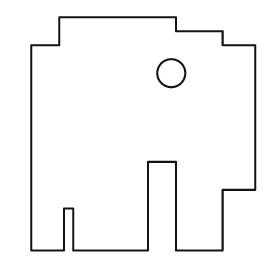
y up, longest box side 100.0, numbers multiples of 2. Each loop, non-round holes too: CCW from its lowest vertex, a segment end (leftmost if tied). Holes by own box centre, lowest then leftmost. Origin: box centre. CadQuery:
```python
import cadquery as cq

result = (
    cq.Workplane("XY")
    .moveTo(-48.0, -50.0)
    .lineTo(-34.0, -50.0)
    .lineTo(-34.0, -32.0)
    .lineTo(-30.0, -32.0)
    .lineTo(-30.0, -50.0)
    .lineTo(2.0, -50.0)
    .lineTo(2.0, -12.0)
    .lineTo(14.0, -12.0)
    .lineTo(14.0, -50.0)
    .lineTo(34.0, -50.0)
    .lineTo(34.0, -24.0)
    .lineTo(48.0, -24.0)
    .lineTo(48.0, 38.0)
    .lineTo(34.0, 38.0)
    .lineTo(34.0, 44.0)
    .lineTo(14.0, 44.0)
    .lineTo(14.0, 50.0)
    .lineTo(-36.0, 50.0)
    .lineTo(-36.0, 38.0)
    .lineTo(-48.0, 38.0)
    .close()
    .moveTo(12.0, 26.0)
    .circle(6.0)
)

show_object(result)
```